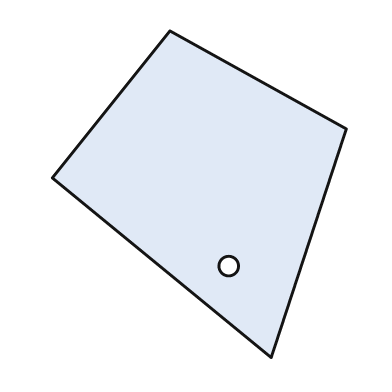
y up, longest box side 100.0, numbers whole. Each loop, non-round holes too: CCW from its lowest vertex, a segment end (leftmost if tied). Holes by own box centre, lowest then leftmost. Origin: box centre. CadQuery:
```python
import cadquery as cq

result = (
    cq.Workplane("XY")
    .moveTo(22.0, -50.0)
    .lineTo(45.0, 20.0)
    .lineTo(-9.0, 50.0)
    .lineTo(-45.0, 5.0)
    .close()
    .moveTo(9.0, -22.0)
    .circle(3.0)
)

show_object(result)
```